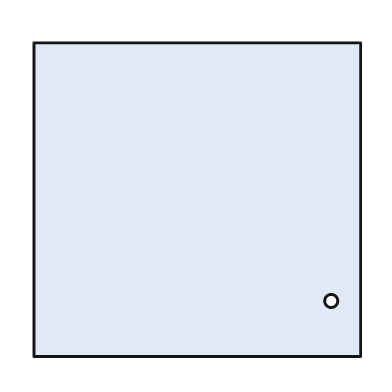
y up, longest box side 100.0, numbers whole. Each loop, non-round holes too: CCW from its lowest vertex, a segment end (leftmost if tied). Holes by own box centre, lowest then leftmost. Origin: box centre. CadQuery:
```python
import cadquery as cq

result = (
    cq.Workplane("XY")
    .moveTo(-50.0, -48.0)
    .lineTo(50.0, -48.0)
    .lineTo(50.0, 48.0)
    .lineTo(-50.0, 48.0)
    .close()
    .moveTo(41.0, -31.0)
    .circle(2.0)
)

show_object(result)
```